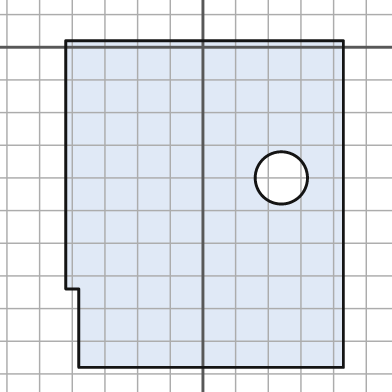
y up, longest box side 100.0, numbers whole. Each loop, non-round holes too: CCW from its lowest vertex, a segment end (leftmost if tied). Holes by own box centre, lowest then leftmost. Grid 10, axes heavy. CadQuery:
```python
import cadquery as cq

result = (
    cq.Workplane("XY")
    .moveTo(-38.0, -98.0)
    .lineTo(43.0, -98.0)
    .lineTo(43.0, 2.0)
    .lineTo(-42.0, 2.0)
    .lineTo(-42.0, -74.0)
    .lineTo(-38.0, -74.0)
    .close()
    .moveTo(24.0, -40.0)
    .circle(8.0)
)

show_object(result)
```